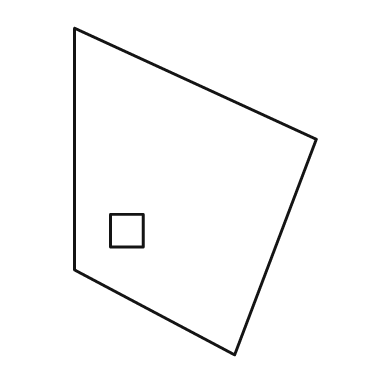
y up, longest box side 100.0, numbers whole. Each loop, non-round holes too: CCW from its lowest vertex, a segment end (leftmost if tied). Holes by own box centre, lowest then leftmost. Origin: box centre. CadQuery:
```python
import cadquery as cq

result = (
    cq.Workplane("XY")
    .moveTo(12.0, -50.0)
    .lineTo(37.0, 16.0)
    .lineTo(-37.0, 50.0)
    .lineTo(-37.0, -24.0)
    .close()
    .moveTo(-26.0, -17.0)
    .lineTo(-16.0, -17.0)
    .lineTo(-16.0, -7.0)
    .lineTo(-26.0, -7.0)
    .close()
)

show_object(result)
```